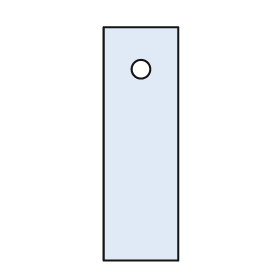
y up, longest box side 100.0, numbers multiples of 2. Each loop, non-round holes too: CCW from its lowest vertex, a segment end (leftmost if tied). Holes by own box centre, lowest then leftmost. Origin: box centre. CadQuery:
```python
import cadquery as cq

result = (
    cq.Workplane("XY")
    .moveTo(-16.0, -50.0)
    .lineTo(16.0, -50.0)
    .lineTo(16.0, 50.0)
    .lineTo(-16.0, 50.0)
    .close()
    .moveTo(0.0, 32.0)
    .circle(4.0)
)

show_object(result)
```